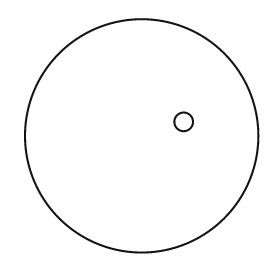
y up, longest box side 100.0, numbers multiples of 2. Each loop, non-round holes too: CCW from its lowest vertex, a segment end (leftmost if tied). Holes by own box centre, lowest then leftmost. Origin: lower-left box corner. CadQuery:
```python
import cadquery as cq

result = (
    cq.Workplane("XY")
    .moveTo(50.0, 50.0)
    .circle(50.0)
    .moveTo(68.0, 56.0)
    .circle(4.0)
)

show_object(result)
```